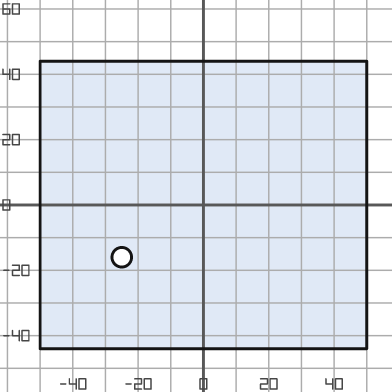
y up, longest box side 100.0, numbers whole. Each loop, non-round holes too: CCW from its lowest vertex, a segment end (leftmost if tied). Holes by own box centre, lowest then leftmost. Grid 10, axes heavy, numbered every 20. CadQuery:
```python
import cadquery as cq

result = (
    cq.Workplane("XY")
    .moveTo(-50.0, -44.0)
    .lineTo(50.0, -44.0)
    .lineTo(50.0, 44.0)
    .lineTo(-50.0, 44.0)
    .close()
    .moveTo(-25.0, -16.0)
    .circle(3.0)
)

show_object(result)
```